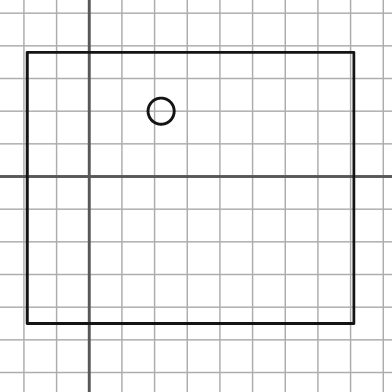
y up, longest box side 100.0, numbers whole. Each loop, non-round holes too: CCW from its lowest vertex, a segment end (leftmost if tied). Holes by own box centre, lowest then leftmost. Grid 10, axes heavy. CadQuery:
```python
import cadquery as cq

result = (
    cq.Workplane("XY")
    .moveTo(-19.0, -45.0)
    .lineTo(81.0, -45.0)
    .lineTo(81.0, 38.0)
    .lineTo(-19.0, 38.0)
    .close()
    .moveTo(22.0, 20.0)
    .circle(4.0)
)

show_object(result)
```